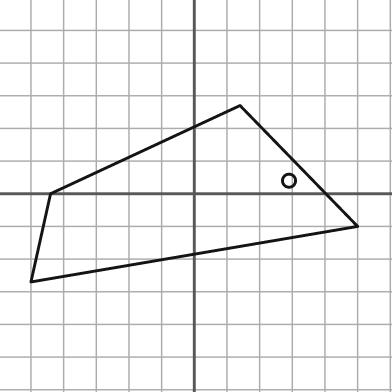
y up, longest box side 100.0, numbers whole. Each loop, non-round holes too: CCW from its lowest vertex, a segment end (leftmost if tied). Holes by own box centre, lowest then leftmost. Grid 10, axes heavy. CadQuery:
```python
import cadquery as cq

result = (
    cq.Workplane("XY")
    .moveTo(-50.0, -27.0)
    .lineTo(50.0, -10.0)
    .lineTo(14.0, 27.0)
    .lineTo(-44.0, 0.0)
    .close()
    .moveTo(29.0, 4.0)
    .circle(2.0)
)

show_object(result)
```